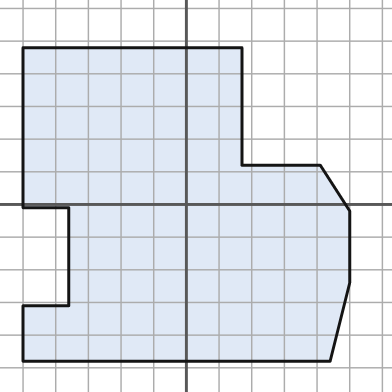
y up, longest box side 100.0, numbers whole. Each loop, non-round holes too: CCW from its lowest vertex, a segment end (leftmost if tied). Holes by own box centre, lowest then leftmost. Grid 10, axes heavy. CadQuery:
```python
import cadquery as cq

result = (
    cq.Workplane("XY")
    .moveTo(-50.0, -48.0)
    .lineTo(44.0, -48.0)
    .lineTo(50.0, -24.0)
    .lineTo(50.0, -2.0)
    .lineTo(41.0, 12.0)
    .lineTo(17.0, 12.0)
    .lineTo(17.0, 48.0)
    .lineTo(-50.0, 48.0)
    .lineTo(-50.0, -1.0)
    .lineTo(-36.0, -1.0)
    .lineTo(-36.0, -31.0)
    .lineTo(-50.0, -31.0)
    .close()
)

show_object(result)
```